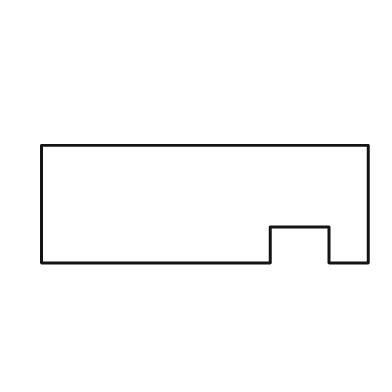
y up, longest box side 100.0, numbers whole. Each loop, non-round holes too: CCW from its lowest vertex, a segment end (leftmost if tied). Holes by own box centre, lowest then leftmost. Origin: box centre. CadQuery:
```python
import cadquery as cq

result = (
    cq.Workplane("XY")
    .moveTo(-50.0, -18.0)
    .lineTo(20.0, -18.0)
    .lineTo(20.0, -7.0)
    .lineTo(38.0, -7.0)
    .lineTo(38.0, -18.0)
    .lineTo(50.0, -18.0)
    .lineTo(50.0, 18.0)
    .lineTo(-50.0, 18.0)
    .close()
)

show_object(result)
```